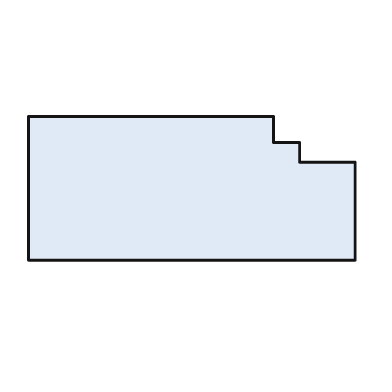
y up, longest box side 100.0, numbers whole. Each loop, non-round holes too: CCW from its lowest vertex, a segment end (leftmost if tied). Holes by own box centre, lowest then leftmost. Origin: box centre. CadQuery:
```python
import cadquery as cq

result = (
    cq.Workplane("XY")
    .moveTo(-50.0, -22.0)
    .lineTo(50.0, -22.0)
    .lineTo(50.0, 8.0)
    .lineTo(33.0, 8.0)
    .lineTo(33.0, 14.0)
    .lineTo(25.0, 14.0)
    .lineTo(25.0, 22.0)
    .lineTo(-50.0, 22.0)
    .close()
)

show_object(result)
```